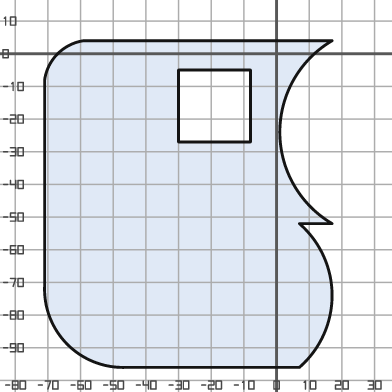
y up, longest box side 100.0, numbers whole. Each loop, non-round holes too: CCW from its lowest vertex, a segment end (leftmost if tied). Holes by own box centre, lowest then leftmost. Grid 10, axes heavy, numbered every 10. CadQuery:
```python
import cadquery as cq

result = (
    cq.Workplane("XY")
    .moveTo(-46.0, -96.0)
    .lineTo(7.0, -96.0)
    .threePointArc((17.0, -74.0), (7.0, -52.0))
    .lineTo(17.0, -52.0)
    .threePointArc((1.0, -24.0), (17.0, 4.0))
    .lineTo(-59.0, 4.0)
    .threePointArc((-67.0, 0.0), (-71.0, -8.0))
    .lineTo(-71.0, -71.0)
    .threePointArc((-64.0, -89.0), (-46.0, -96.0))
    .close()
    .moveTo(-30.0, -27.0)
    .lineTo(-8.0, -27.0)
    .lineTo(-8.0, -5.0)
    .lineTo(-30.0, -5.0)
    .close()
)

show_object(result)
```